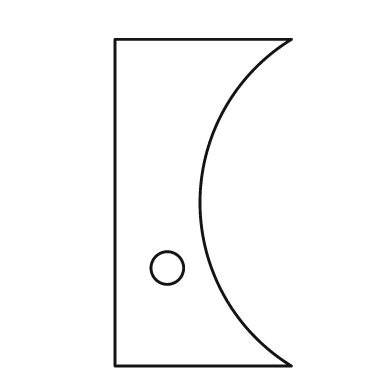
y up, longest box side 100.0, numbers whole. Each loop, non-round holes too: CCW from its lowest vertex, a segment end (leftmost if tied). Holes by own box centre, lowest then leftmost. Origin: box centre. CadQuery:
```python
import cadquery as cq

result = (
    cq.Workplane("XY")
    .moveTo(-27.0, -50.0)
    .lineTo(27.0, -50.0)
    .threePointArc((-1.0, 0.0), (27.0, 50.0))
    .lineTo(-27.0, 50.0)
    .close()
    .moveTo(-11.0, -20.0)
    .circle(5.0)
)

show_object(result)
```